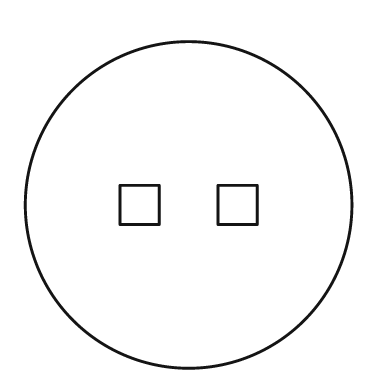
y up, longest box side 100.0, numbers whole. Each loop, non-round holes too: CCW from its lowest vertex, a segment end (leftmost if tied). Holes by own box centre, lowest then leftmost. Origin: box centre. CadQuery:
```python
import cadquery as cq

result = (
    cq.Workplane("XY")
    .moveTo(0.0, 0.0)
    .circle(50.0)
    .moveTo(-21.0, -6.0)
    .lineTo(-9.0, -6.0)
    .lineTo(-9.0, 6.0)
    .lineTo(-21.0, 6.0)
    .close()
    .moveTo(9.0, -6.0)
    .lineTo(21.0, -6.0)
    .lineTo(21.0, 6.0)
    .lineTo(9.0, 6.0)
    .close()
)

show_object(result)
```